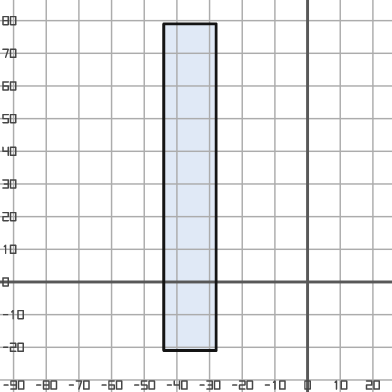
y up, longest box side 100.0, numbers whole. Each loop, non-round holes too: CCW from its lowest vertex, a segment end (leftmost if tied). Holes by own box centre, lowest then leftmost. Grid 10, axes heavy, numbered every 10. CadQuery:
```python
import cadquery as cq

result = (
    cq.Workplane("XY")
    .moveTo(-44.0, -21.0)
    .lineTo(-28.0, -21.0)
    .lineTo(-28.0, 79.0)
    .lineTo(-44.0, 79.0)
    .close()
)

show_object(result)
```